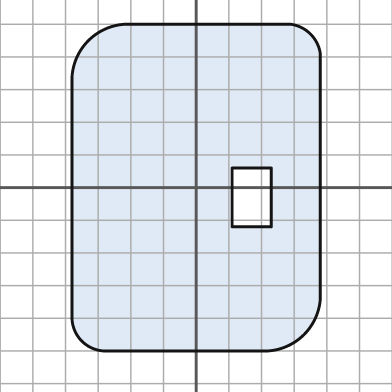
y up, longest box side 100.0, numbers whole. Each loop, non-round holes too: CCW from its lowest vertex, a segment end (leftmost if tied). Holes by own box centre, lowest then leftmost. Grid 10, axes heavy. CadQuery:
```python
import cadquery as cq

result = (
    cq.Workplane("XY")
    .moveTo(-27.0, -50.0)
    .lineTo(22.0, -50.0)
    .threePointArc((33.0, -45.0), (38.0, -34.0))
    .lineTo(38.0, 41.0)
    .threePointArc((35.0, 47.0), (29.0, 50.0))
    .lineTo(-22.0, 50.0)
    .threePointArc((-33.0, 45.0), (-38.0, 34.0))
    .lineTo(-38.0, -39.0)
    .threePointArc((-35.0, -47.0), (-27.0, -50.0))
    .close()
    .moveTo(11.0, -12.0)
    .lineTo(23.0, -12.0)
    .lineTo(23.0, 6.0)
    .lineTo(11.0, 6.0)
    .close()
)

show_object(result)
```